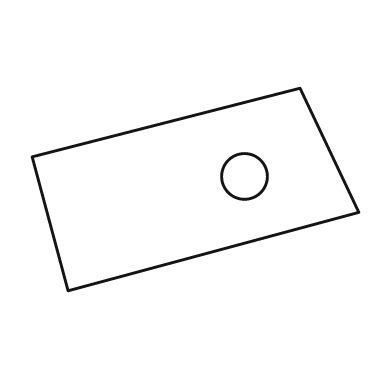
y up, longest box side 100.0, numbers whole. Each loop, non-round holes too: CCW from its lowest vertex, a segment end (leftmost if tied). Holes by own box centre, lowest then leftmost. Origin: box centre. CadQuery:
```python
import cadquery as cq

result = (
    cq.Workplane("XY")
    .moveTo(-39.0, -31.0)
    .lineTo(50.0, -7.0)
    .lineTo(32.0, 31.0)
    .lineTo(-50.0, 10.0)
    .close()
    .moveTo(15.0, 4.0)
    .circle(7.0)
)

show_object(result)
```